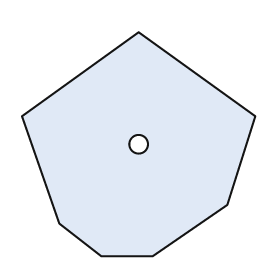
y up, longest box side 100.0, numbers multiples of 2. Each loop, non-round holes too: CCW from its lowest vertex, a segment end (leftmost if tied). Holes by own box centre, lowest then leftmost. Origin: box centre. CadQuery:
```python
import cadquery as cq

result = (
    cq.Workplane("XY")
    .moveTo(-16.0, -48.0)
    .lineTo(6.0, -48.0)
    .lineTo(38.0, -26.0)
    .lineTo(50.0, 12.0)
    .lineTo(0.0, 48.0)
    .lineTo(-50.0, 12.0)
    .lineTo(-34.0, -34.0)
    .close()
    .moveTo(0.0, 0.0)
    .circle(4.0)
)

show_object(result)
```